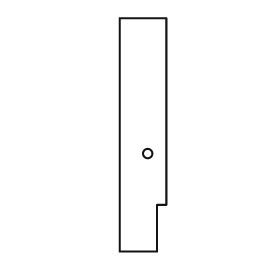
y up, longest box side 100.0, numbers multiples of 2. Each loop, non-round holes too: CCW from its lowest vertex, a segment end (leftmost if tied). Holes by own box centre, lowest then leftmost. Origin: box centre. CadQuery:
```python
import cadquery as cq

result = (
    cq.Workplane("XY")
    .moveTo(-10.0, -50.0)
    .lineTo(6.0, -50.0)
    .lineTo(6.0, -30.0)
    .lineTo(10.0, -30.0)
    .lineTo(10.0, 50.0)
    .lineTo(-10.0, 50.0)
    .close()
    .moveTo(2.0, -8.0)
    .circle(2.0)
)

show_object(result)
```